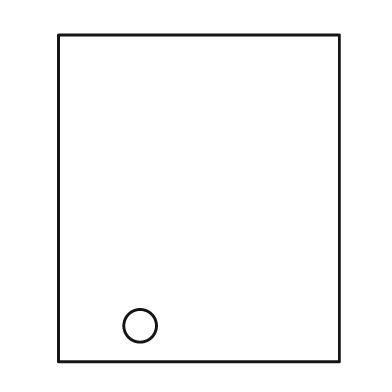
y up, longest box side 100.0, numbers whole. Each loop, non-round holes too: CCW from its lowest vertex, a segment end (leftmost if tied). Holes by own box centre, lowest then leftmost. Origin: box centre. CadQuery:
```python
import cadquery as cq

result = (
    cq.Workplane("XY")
    .moveTo(-43.0, -50.0)
    .lineTo(43.0, -50.0)
    .lineTo(43.0, 50.0)
    .lineTo(-43.0, 50.0)
    .close()
    .moveTo(-18.0, -39.0)
    .circle(5.0)
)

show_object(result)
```